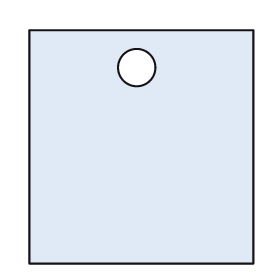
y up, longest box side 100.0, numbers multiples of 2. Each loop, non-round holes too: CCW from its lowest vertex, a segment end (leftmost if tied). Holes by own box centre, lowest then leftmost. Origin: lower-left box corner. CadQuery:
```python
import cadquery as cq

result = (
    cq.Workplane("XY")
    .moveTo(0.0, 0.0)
    .lineTo(96.0, 0.0)
    .lineTo(96.0, 100.0)
    .lineTo(0.0, 100.0)
    .close()
    .moveTo(46.0, 84.0)
    .circle(8.0)
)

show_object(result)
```